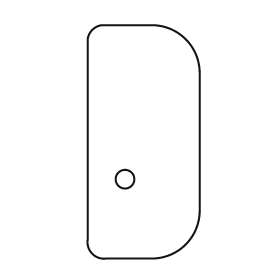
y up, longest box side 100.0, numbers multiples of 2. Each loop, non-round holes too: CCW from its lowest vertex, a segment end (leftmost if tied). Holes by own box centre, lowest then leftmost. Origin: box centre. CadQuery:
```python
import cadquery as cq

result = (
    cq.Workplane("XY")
    .moveTo(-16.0, -50.0)
    .lineTo(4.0, -50.0)
    .threePointArc((18.0, -44.0), (24.0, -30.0))
    .lineTo(24.0, 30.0)
    .threePointArc((18.0, 44.0), (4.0, 50.0))
    .lineTo(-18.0, 50.0)
    .threePointArc((-22.0, 48.0), (-24.0, 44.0))
    .lineTo(-24.0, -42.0)
    .threePointArc((-22.0, -48.0), (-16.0, -50.0))
    .close()
    .moveTo(-8.0, -16.0)
    .circle(4.0)
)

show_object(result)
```